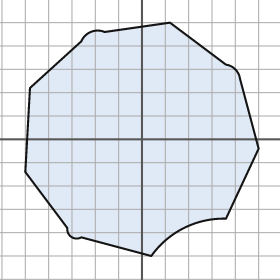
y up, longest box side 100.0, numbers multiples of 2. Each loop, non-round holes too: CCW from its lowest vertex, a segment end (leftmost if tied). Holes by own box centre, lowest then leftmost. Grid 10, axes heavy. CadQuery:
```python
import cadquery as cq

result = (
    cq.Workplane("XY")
    .moveTo(4.0, -50.0)
    .threePointArc((18.0, -38.0), (36.0, -34.0))
    .lineTo(50.0, -4.0)
    .lineTo(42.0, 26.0)
    .threePointArc((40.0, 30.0), (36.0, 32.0))
    .lineTo(12.0, 50.0)
    .lineTo(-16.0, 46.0)
    .threePointArc((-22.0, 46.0), (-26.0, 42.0))
    .lineTo(-48.0, 22.0)
    .lineTo(-50.0, -14.0)
    .lineTo(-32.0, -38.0)
    .threePointArc((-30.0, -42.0), (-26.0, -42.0))
    .close()
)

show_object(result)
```